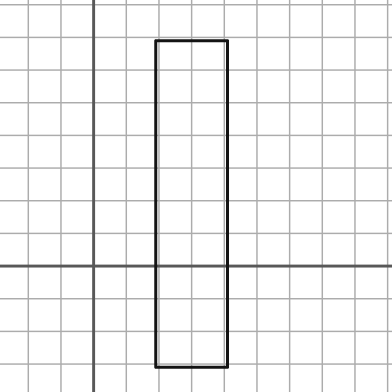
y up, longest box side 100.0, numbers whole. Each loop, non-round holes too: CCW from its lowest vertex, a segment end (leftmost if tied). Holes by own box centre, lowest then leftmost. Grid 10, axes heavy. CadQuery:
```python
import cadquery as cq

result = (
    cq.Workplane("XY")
    .moveTo(19.0, -31.0)
    .lineTo(41.0, -31.0)
    .lineTo(41.0, 69.0)
    .lineTo(19.0, 69.0)
    .close()
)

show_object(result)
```